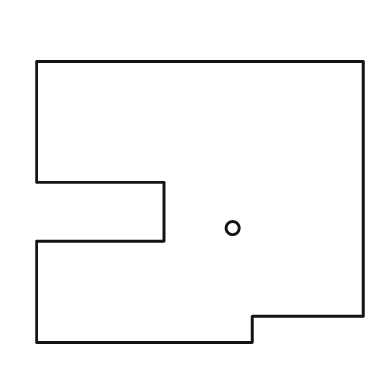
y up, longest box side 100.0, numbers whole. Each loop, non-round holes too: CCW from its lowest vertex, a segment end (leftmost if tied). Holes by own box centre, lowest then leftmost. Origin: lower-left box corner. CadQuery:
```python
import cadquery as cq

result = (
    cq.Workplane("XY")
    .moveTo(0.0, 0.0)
    .lineTo(66.0, 0.0)
    .lineTo(66.0, 8.0)
    .lineTo(100.0, 8.0)
    .lineTo(100.0, 86.0)
    .lineTo(0.0, 86.0)
    .lineTo(0.0, 49.0)
    .lineTo(39.0, 49.0)
    .lineTo(39.0, 31.0)
    .lineTo(0.0, 31.0)
    .close()
    .moveTo(60.0, 35.0)
    .circle(2.0)
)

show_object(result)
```